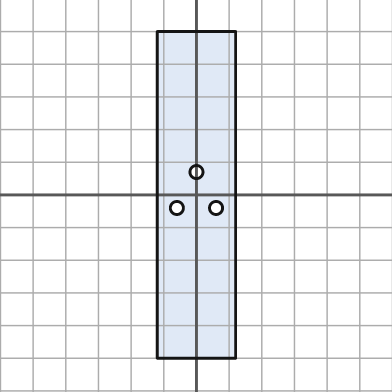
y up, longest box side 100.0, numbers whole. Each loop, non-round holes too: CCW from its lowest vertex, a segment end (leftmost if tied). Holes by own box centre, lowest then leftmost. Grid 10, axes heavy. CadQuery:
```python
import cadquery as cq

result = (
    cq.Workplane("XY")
    .moveTo(-12.0, -50.0)
    .lineTo(12.0, -50.0)
    .lineTo(12.0, 50.0)
    .lineTo(-12.0, 50.0)
    .close()
    .moveTo(-6.0, -4.0)
    .circle(2.0)
    .moveTo(6.0, -4.0)
    .circle(2.0)
    .moveTo(0.0, 7.0)
    .circle(2.0)
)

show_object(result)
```